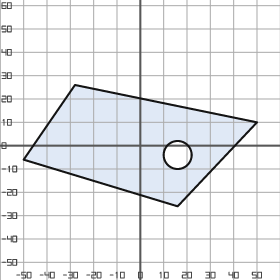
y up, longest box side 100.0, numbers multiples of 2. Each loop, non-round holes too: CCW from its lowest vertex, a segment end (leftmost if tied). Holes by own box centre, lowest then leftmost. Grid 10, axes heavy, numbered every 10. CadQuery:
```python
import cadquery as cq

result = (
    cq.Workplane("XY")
    .moveTo(16.0, -26.0)
    .lineTo(50.0, 10.0)
    .lineTo(-28.0, 26.0)
    .lineTo(-50.0, -6.0)
    .close()
    .moveTo(16.0, -4.0)
    .circle(6.0)
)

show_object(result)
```